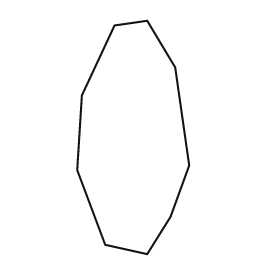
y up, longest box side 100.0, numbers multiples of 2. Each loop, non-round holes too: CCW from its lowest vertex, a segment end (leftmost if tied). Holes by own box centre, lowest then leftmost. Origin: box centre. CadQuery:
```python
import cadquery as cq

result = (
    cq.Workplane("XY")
    .moveTo(6.0, -50.0)
    .lineTo(16.0, -34.0)
    .lineTo(24.0, -12.0)
    .lineTo(18.0, 30.0)
    .lineTo(6.0, 50.0)
    .lineTo(-8.0, 48.0)
    .lineTo(-22.0, 18.0)
    .lineTo(-24.0, -14.0)
    .lineTo(-12.0, -46.0)
    .close()
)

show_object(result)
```